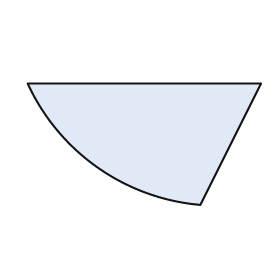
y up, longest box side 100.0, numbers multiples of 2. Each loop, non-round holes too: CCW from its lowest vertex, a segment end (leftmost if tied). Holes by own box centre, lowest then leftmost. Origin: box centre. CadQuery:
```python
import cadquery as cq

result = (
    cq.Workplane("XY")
    .moveTo(24.0, -26.0)
    .lineTo(50.0, 26.0)
    .lineTo(-50.0, 26.0)
    .threePointArc((-20.0, -10.0), (24.0, -26.0))
    .close()
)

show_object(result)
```